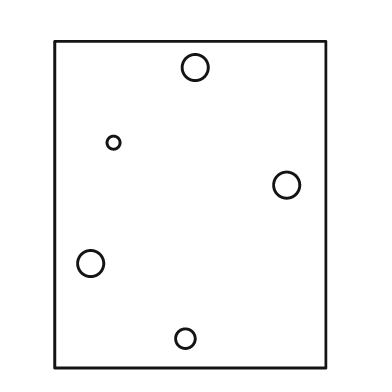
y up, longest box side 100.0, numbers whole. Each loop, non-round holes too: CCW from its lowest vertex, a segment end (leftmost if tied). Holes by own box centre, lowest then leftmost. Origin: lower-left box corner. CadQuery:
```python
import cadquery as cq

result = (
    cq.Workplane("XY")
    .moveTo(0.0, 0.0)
    .lineTo(83.0, 0.0)
    .lineTo(83.0, 100.0)
    .lineTo(0.0, 100.0)
    .close()
    .moveTo(40.0, 9.0)
    .circle(3.0)
    .moveTo(11.0, 32.0)
    .circle(4.0)
    .moveTo(71.0, 56.0)
    .circle(4.0)
    .moveTo(18.0, 69.0)
    .circle(2.0)
    .moveTo(43.0, 92.0)
    .circle(4.0)
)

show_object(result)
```